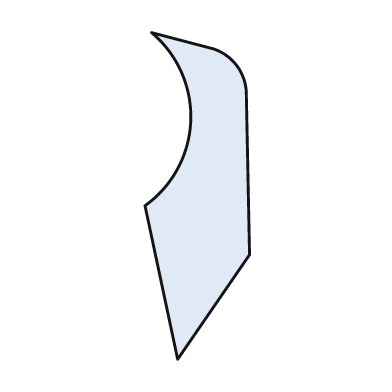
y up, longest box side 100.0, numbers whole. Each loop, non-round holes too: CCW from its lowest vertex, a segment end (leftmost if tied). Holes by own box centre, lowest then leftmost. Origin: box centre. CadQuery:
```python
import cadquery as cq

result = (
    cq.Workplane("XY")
    .moveTo(-6.0, -50.0)
    .lineTo(16.0, -18.0)
    .lineTo(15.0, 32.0)
    .threePointArc((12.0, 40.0), (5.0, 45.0))
    .lineTo(-14.0, 50.0)
    .threePointArc((-2.0, 23.0), (-16.0, -3.0))
    .close()
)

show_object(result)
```